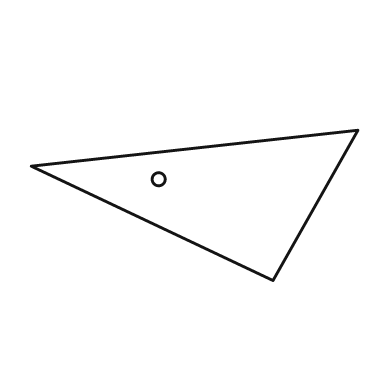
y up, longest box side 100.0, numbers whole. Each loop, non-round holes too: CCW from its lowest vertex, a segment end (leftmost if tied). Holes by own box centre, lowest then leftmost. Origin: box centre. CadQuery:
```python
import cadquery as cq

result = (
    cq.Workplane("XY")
    .moveTo(24.0, -23.0)
    .lineTo(50.0, 23.0)
    .lineTo(-50.0, 12.0)
    .close()
    .moveTo(-11.0, 8.0)
    .circle(2.0)
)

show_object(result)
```